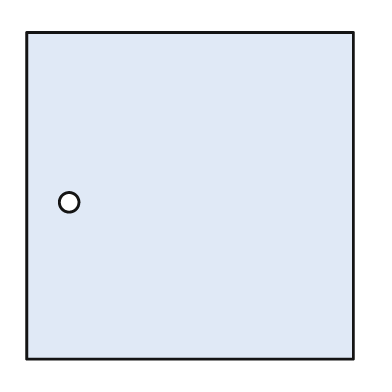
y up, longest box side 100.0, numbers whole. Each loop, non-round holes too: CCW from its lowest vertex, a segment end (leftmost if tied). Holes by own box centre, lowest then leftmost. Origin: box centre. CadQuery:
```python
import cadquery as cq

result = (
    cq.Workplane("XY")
    .moveTo(-50.0, -50.0)
    .lineTo(50.0, -50.0)
    .lineTo(50.0, 50.0)
    .lineTo(-50.0, 50.0)
    .close()
    .moveTo(-37.0, -2.0)
    .circle(3.0)
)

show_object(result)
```